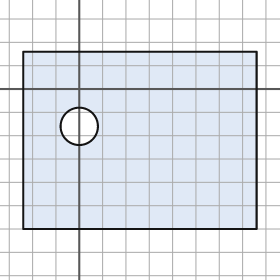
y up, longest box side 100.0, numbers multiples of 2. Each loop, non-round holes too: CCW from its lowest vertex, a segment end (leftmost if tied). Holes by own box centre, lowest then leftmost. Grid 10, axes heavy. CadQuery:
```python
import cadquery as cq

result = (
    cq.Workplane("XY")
    .moveTo(-24.0, -60.0)
    .lineTo(76.0, -60.0)
    .lineTo(76.0, 16.0)
    .lineTo(-24.0, 16.0)
    .close()
    .moveTo(0.0, -16.0)
    .circle(8.0)
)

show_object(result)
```